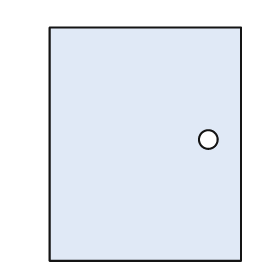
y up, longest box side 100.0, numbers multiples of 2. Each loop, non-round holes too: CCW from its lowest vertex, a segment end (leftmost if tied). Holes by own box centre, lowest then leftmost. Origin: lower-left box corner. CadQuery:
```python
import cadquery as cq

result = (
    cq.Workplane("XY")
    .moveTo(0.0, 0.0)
    .lineTo(82.0, 0.0)
    .lineTo(82.0, 100.0)
    .lineTo(0.0, 100.0)
    .close()
    .moveTo(68.0, 52.0)
    .circle(4.0)
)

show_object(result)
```